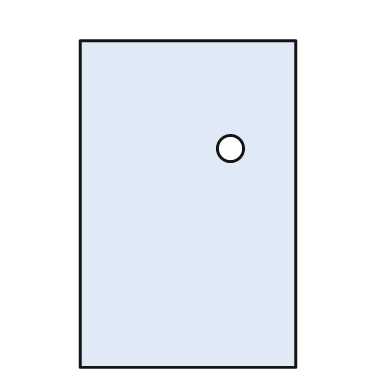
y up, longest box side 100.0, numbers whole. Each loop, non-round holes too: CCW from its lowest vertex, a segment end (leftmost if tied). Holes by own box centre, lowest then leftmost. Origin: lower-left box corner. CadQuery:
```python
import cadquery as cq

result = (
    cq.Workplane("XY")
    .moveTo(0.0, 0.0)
    .lineTo(66.0, 0.0)
    .lineTo(66.0, 100.0)
    .lineTo(0.0, 100.0)
    .close()
    .moveTo(46.0, 67.0)
    .circle(4.0)
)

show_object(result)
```